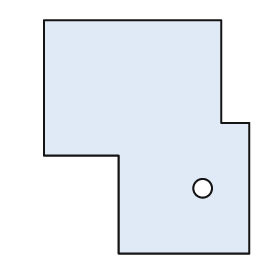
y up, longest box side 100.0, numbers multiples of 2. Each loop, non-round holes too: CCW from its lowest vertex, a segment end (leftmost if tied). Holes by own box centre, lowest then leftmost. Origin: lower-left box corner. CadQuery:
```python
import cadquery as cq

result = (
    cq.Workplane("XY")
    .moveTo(32.0, 0.0)
    .lineTo(88.0, 0.0)
    .lineTo(88.0, 56.0)
    .lineTo(76.0, 56.0)
    .lineTo(76.0, 100.0)
    .lineTo(0.0, 100.0)
    .lineTo(0.0, 42.0)
    .lineTo(32.0, 42.0)
    .close()
    .moveTo(68.0, 28.0)
    .circle(4.0)
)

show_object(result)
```